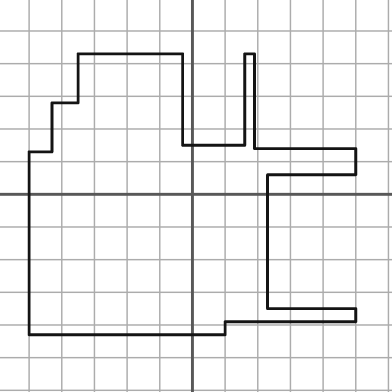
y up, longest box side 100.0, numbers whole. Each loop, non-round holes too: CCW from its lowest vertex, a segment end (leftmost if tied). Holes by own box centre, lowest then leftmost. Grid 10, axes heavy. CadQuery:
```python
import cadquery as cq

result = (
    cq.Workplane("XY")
    .moveTo(-50.0, -43.0)
    .lineTo(10.0, -43.0)
    .lineTo(10.0, -39.0)
    .lineTo(50.0, -39.0)
    .lineTo(50.0, -35.0)
    .lineTo(23.0, -35.0)
    .lineTo(23.0, 6.0)
    .lineTo(50.0, 6.0)
    .lineTo(50.0, 14.0)
    .lineTo(19.0, 14.0)
    .lineTo(19.0, 43.0)
    .lineTo(16.0, 43.0)
    .lineTo(16.0, 15.0)
    .lineTo(-3.0, 15.0)
    .lineTo(-3.0, 43.0)
    .lineTo(-35.0, 43.0)
    .lineTo(-35.0, 28.0)
    .lineTo(-43.0, 28.0)
    .lineTo(-43.0, 13.0)
    .lineTo(-50.0, 13.0)
    .close()
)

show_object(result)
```